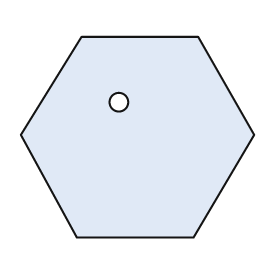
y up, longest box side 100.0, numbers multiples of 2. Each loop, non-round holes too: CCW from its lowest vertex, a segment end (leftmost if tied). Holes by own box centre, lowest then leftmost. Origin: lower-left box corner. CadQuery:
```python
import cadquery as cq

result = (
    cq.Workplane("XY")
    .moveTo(24.0, 0.0)
    .lineTo(74.0, 0.0)
    .lineTo(100.0, 44.0)
    .lineTo(76.0, 86.0)
    .lineTo(26.0, 86.0)
    .lineTo(0.0, 44.0)
    .close()
    .moveTo(42.0, 58.0)
    .circle(4.0)
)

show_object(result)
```